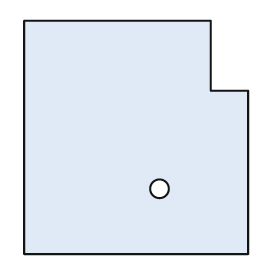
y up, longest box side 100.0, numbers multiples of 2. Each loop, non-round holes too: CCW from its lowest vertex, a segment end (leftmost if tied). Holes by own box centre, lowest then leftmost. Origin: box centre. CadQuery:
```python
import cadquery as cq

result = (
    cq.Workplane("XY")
    .moveTo(-48.0, -50.0)
    .lineTo(48.0, -50.0)
    .lineTo(48.0, 20.0)
    .lineTo(32.0, 20.0)
    .lineTo(32.0, 50.0)
    .lineTo(-48.0, 50.0)
    .close()
    .moveTo(10.0, -22.0)
    .circle(4.0)
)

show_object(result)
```